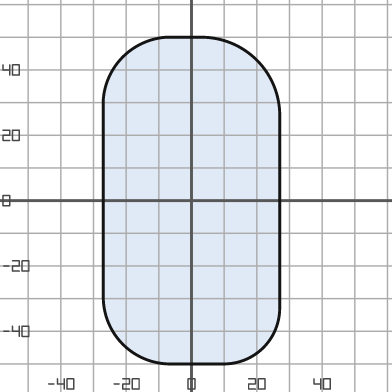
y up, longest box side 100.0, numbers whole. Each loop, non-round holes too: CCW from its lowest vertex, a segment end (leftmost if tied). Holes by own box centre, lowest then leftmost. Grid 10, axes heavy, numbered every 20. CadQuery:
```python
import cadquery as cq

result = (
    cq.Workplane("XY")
    .moveTo(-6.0, -50.0)
    .lineTo(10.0, -50.0)
    .threePointArc((22.0, -45.0), (27.0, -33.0))
    .lineTo(27.0, 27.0)
    .threePointArc((20.0, 43.0), (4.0, 50.0))
    .lineTo(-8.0, 50.0)
    .threePointArc((-21.0, 44.0), (-27.0, 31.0))
    .lineTo(-27.0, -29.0)
    .threePointArc((-21.0, -44.0), (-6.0, -50.0))
    .close()
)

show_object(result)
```